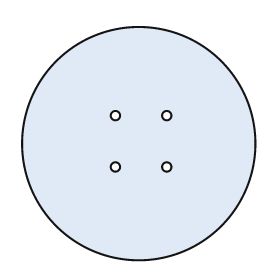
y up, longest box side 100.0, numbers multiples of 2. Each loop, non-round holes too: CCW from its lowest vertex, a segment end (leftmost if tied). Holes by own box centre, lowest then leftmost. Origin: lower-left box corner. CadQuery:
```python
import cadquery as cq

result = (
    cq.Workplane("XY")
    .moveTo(50.0, 50.0)
    .circle(50.0)
    .moveTo(40.0, 40.0)
    .circle(2.0)
    .moveTo(62.0, 40.0)
    .circle(2.0)
    .moveTo(40.0, 62.0)
    .circle(2.0)
    .moveTo(62.0, 62.0)
    .circle(2.0)
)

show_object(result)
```